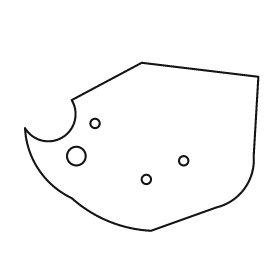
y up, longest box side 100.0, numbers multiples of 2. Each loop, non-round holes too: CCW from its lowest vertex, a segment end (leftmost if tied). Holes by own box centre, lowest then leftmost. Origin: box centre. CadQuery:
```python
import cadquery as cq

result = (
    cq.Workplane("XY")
    .moveTo(4.0, -36.0)
    .lineTo(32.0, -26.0)
    .threePointArc((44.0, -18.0), (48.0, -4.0))
    .lineTo(50.0, 30.0)
    .lineTo(0.0, 36.0)
    .lineTo(-30.0, 20.0)
    .threePointArc((-34.0, 4.0), (-50.0, 8.0))
    .threePointArc((-44.0, -10.0), (-30.0, -22.0))
    .threePointArc((-14.0, -32.0), (4.0, -36.0))
    .close()
    .moveTo(2.0, -14.0)
    .circle(2.0)
    .moveTo(18.0, -6.0)
    .circle(2.0)
    .moveTo(-28.0, -4.0)
    .circle(4.0)
    .moveTo(-20.0, 10.0)
    .circle(2.0)
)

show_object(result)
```